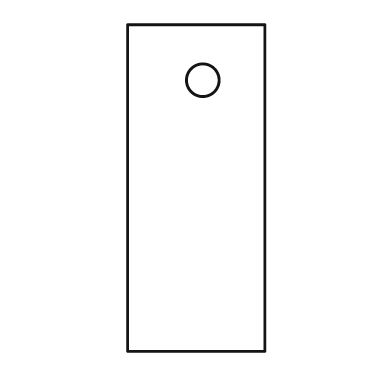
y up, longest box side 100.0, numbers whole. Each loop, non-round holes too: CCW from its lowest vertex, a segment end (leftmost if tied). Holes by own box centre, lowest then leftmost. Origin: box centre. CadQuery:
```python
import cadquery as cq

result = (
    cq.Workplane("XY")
    .moveTo(-21.0, -50.0)
    .lineTo(21.0, -50.0)
    .lineTo(21.0, 50.0)
    .lineTo(-21.0, 50.0)
    .close()
    .moveTo(2.0, 33.0)
    .circle(5.0)
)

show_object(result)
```